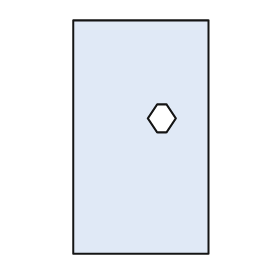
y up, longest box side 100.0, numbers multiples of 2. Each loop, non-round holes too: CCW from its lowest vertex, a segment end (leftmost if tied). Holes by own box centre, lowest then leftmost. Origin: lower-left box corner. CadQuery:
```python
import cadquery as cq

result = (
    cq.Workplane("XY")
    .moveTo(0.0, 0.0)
    .lineTo(58.0, 0.0)
    .lineTo(58.0, 100.0)
    .lineTo(0.0, 100.0)
    .close()
    .moveTo(36.0, 52.0)
    .lineTo(40.0, 52.0)
    .lineTo(44.0, 58.0)
    .lineTo(40.0, 64.0)
    .lineTo(36.0, 64.0)
    .lineTo(32.0, 58.0)
    .close()
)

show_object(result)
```